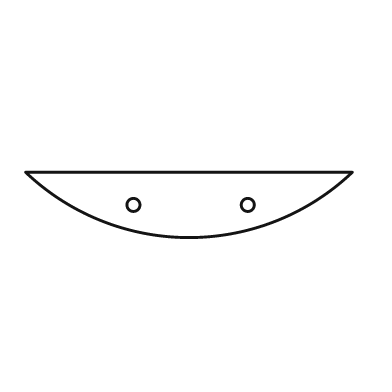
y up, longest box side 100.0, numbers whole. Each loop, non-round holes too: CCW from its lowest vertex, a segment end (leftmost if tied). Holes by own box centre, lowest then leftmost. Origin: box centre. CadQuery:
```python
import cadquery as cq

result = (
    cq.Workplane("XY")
    .moveTo(-50.0, 10.0)
    .threePointArc((0.0, -10.0), (50.0, 10.0))
    .close()
    .moveTo(-17.0, 0.0)
    .circle(2.0)
    .moveTo(18.0, 0.0)
    .circle(2.0)
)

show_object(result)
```